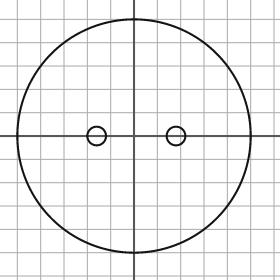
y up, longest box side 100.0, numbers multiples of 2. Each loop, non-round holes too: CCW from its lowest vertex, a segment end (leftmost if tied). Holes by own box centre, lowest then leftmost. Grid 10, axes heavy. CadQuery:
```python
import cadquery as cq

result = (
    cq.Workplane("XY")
    .moveTo(0.0, 0.0)
    .circle(50.0)
    .moveTo(-16.0, 0.0)
    .circle(4.0)
    .moveTo(18.0, 0.0)
    .circle(4.0)
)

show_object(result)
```